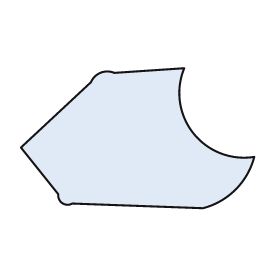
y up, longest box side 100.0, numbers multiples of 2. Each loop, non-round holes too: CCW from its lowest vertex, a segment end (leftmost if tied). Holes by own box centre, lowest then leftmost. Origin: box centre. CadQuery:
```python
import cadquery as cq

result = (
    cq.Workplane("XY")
    .moveTo(28.0, -30.0)
    .threePointArc((42.0, -22.0), (50.0, -8.0))
    .threePointArc((24.0, 2.0), (20.0, 30.0))
    .lineTo(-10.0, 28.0)
    .threePointArc((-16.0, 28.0), (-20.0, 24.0))
    .lineTo(-50.0, -4.0)
    .lineTo(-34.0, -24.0)
    .threePointArc((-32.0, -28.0), (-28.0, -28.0))
    .close()
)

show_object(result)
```